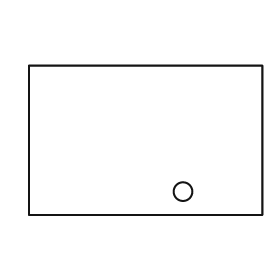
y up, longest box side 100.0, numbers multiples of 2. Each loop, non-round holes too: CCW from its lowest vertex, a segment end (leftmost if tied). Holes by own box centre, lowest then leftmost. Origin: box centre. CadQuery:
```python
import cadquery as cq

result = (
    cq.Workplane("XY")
    .moveTo(-50.0, -32.0)
    .lineTo(50.0, -32.0)
    .lineTo(50.0, 32.0)
    .lineTo(-50.0, 32.0)
    .close()
    .moveTo(16.0, -22.0)
    .circle(4.0)
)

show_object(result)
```